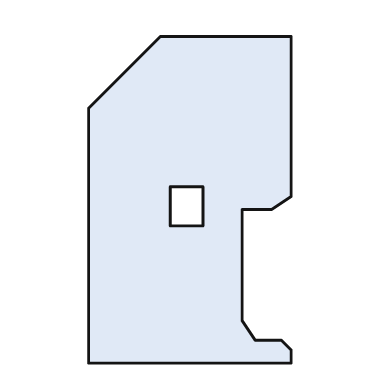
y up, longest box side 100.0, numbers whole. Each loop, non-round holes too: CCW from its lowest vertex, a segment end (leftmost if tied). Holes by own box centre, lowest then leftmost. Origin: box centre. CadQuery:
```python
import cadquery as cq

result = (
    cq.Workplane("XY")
    .moveTo(-31.0, -50.0)
    .lineTo(31.0, -50.0)
    .lineTo(31.0, -46.0)
    .lineTo(28.0, -43.0)
    .lineTo(20.0, -43.0)
    .lineTo(16.0, -37.0)
    .lineTo(16.0, -3.0)
    .lineTo(25.0, -3.0)
    .lineTo(31.0, 1.0)
    .lineTo(31.0, 50.0)
    .lineTo(-9.0, 50.0)
    .lineTo(-31.0, 28.0)
    .close()
    .moveTo(-6.0, -8.0)
    .lineTo(4.0, -8.0)
    .lineTo(4.0, 4.0)
    .lineTo(-6.0, 4.0)
    .close()
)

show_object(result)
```